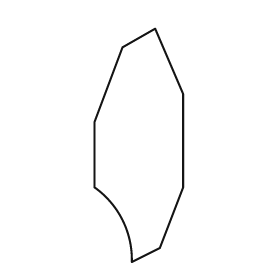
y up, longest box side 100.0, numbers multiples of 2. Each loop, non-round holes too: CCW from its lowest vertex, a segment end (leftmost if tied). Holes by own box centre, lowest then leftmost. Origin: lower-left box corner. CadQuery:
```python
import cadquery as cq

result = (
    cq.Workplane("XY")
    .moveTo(16.0, 0.0)
    .lineTo(28.0, 6.0)
    .lineTo(38.0, 32.0)
    .lineTo(38.0, 72.0)
    .lineTo(26.0, 100.0)
    .lineTo(12.0, 92.0)
    .lineTo(0.0, 60.0)
    .lineTo(0.0, 32.0)
    .threePointArc((12.0, 18.0), (16.0, 0.0))
    .close()
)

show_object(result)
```